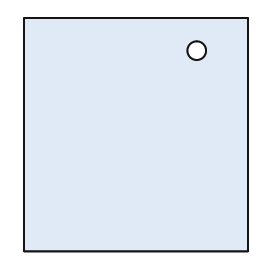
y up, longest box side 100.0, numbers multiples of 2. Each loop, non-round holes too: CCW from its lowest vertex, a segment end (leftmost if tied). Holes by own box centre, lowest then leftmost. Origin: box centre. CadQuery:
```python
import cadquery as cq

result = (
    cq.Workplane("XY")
    .moveTo(-48.0, -50.0)
    .lineTo(48.0, -50.0)
    .lineTo(48.0, 50.0)
    .lineTo(-48.0, 50.0)
    .close()
    .moveTo(26.0, 36.0)
    .circle(4.0)
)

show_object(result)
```